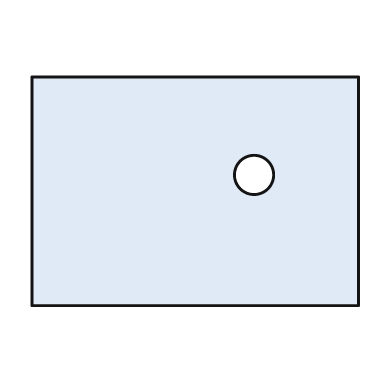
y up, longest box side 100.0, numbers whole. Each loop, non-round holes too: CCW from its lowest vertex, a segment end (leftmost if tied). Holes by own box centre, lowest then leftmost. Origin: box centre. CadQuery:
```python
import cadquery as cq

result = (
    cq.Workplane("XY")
    .moveTo(-50.0, -35.0)
    .lineTo(50.0, -35.0)
    .lineTo(50.0, 35.0)
    .lineTo(-50.0, 35.0)
    .close()
    .moveTo(18.0, 5.0)
    .circle(6.0)
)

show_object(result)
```